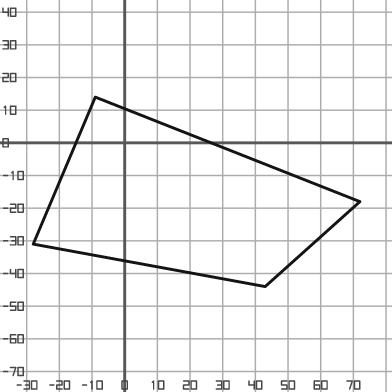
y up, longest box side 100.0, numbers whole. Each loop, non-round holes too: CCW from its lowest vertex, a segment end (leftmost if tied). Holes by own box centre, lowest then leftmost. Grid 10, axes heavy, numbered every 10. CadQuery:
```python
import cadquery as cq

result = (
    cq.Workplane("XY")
    .moveTo(43.0, -44.0)
    .lineTo(72.0, -18.0)
    .lineTo(-9.0, 14.0)
    .lineTo(-28.0, -31.0)
    .close()
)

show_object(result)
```